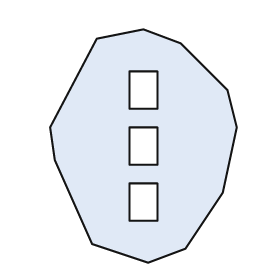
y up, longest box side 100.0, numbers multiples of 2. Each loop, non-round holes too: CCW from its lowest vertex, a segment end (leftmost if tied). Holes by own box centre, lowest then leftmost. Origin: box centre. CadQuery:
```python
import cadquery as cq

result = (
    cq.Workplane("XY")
    .moveTo(2.0, -50.0)
    .lineTo(18.0, -44.0)
    .lineTo(34.0, -20.0)
    .lineTo(40.0, 8.0)
    .lineTo(36.0, 24.0)
    .lineTo(16.0, 44.0)
    .lineTo(0.0, 50.0)
    .lineTo(-20.0, 46.0)
    .lineTo(-40.0, 8.0)
    .lineTo(-38.0, -6.0)
    .lineTo(-22.0, -42.0)
    .close()
    .moveTo(-6.0, -32.0)
    .lineTo(6.0, -32.0)
    .lineTo(6.0, -16.0)
    .lineTo(-6.0, -16.0)
    .close()
    .moveTo(-6.0, -8.0)
    .lineTo(6.0, -8.0)
    .lineTo(6.0, 8.0)
    .lineTo(-6.0, 8.0)
    .close()
    .moveTo(-6.0, 16.0)
    .lineTo(6.0, 16.0)
    .lineTo(6.0, 32.0)
    .lineTo(-6.0, 32.0)
    .close()
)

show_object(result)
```